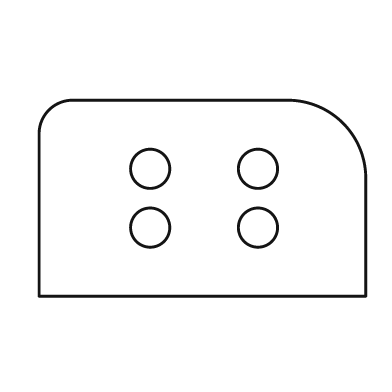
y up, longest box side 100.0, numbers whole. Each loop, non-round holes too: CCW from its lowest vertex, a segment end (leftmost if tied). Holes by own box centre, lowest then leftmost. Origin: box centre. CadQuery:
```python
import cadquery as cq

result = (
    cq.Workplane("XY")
    .moveTo(-50.0, -30.0)
    .lineTo(50.0, -30.0)
    .lineTo(50.0, 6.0)
    .threePointArc((43.0, 23.0), (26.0, 30.0))
    .lineTo(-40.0, 30.0)
    .threePointArc((-47.0, 27.0), (-50.0, 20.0))
    .close()
    .moveTo(-16.0, -9.0)
    .circle(6.0)
    .moveTo(17.0, -9.0)
    .circle(6.0)
    .moveTo(-16.0, 9.0)
    .circle(6.0)
    .moveTo(17.0, 9.0)
    .circle(6.0)
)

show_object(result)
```